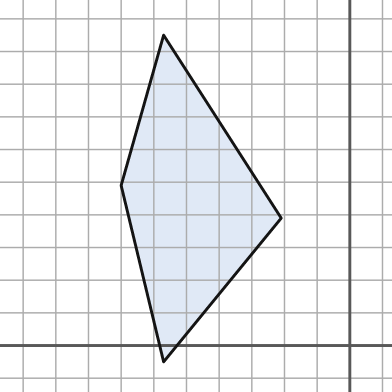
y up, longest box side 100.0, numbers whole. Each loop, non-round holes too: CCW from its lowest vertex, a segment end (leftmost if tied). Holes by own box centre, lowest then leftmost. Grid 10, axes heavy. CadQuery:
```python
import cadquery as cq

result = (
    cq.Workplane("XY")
    .moveTo(-57.0, -5.0)
    .lineTo(-21.0, 39.0)
    .lineTo(-57.0, 95.0)
    .lineTo(-70.0, 49.0)
    .close()
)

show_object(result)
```